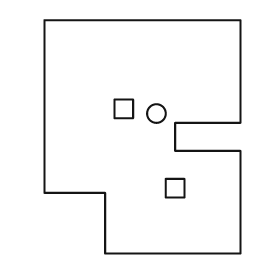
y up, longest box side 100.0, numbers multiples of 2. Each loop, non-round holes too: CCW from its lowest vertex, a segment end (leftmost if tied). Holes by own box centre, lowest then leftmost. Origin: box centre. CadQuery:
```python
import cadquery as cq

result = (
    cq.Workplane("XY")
    .moveTo(-16.0, -50.0)
    .lineTo(42.0, -50.0)
    .lineTo(42.0, -6.0)
    .lineTo(14.0, -6.0)
    .lineTo(14.0, 6.0)
    .lineTo(42.0, 6.0)
    .lineTo(42.0, 50.0)
    .lineTo(-42.0, 50.0)
    .lineTo(-42.0, -24.0)
    .lineTo(-16.0, -24.0)
    .close()
    .moveTo(10.0, -26.0)
    .lineTo(18.0, -26.0)
    .lineTo(18.0, -18.0)
    .lineTo(10.0, -18.0)
    .close()
    .moveTo(6.0, 10.0)
    .circle(4.0)
    .moveTo(-12.0, 8.0)
    .lineTo(-4.0, 8.0)
    .lineTo(-4.0, 16.0)
    .lineTo(-12.0, 16.0)
    .close()
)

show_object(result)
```